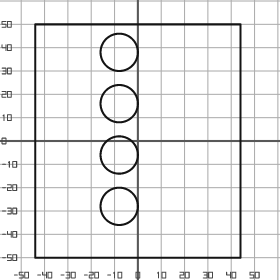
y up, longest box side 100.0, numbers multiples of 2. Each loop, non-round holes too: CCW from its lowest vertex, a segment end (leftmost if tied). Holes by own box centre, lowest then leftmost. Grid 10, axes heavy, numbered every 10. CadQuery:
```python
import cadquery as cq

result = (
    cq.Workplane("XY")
    .moveTo(-44.0, -50.0)
    .lineTo(44.0, -50.0)
    .lineTo(44.0, 50.0)
    .lineTo(-44.0, 50.0)
    .close()
    .moveTo(-8.0, -28.0)
    .circle(8.0)
    .moveTo(-8.0, -6.0)
    .circle(8.0)
    .moveTo(-8.0, 16.0)
    .circle(8.0)
    .moveTo(-8.0, 38.0)
    .circle(8.0)
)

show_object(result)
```